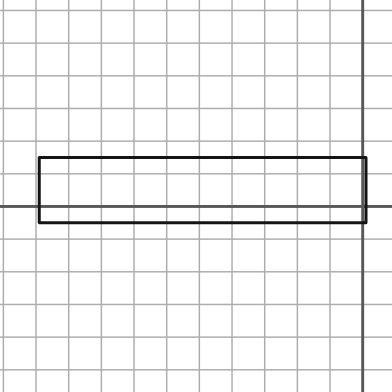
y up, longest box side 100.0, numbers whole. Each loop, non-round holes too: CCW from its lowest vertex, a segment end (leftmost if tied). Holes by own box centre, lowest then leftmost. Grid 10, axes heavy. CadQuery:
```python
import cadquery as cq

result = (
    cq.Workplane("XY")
    .moveTo(-99.0, -5.0)
    .lineTo(1.0, -5.0)
    .lineTo(1.0, 15.0)
    .lineTo(-99.0, 15.0)
    .close()
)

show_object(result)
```